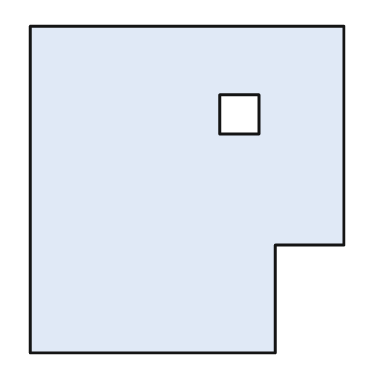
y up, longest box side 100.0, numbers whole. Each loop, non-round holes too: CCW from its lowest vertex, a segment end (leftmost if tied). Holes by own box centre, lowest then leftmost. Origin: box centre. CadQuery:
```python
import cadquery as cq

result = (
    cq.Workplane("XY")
    .moveTo(-48.0, -50.0)
    .lineTo(27.0, -50.0)
    .lineTo(27.0, -17.0)
    .lineTo(48.0, -17.0)
    .lineTo(48.0, 50.0)
    .lineTo(-48.0, 50.0)
    .close()
    .moveTo(10.0, 17.0)
    .lineTo(22.0, 17.0)
    .lineTo(22.0, 29.0)
    .lineTo(10.0, 29.0)
    .close()
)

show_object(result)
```